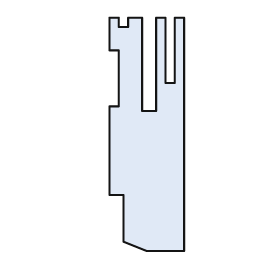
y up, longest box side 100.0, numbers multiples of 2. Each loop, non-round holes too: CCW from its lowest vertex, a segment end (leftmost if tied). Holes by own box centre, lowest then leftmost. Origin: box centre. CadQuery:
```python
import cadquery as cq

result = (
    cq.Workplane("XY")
    .moveTo(0.0, -50.0)
    .lineTo(16.0, -50.0)
    .lineTo(16.0, 50.0)
    .lineTo(12.0, 50.0)
    .lineTo(12.0, 22.0)
    .lineTo(8.0, 22.0)
    .lineTo(8.0, 50.0)
    .lineTo(4.0, 50.0)
    .lineTo(4.0, 10.0)
    .lineTo(-2.0, 10.0)
    .lineTo(-2.0, 50.0)
    .lineTo(-8.0, 50.0)
    .lineTo(-8.0, 46.0)
    .lineTo(-12.0, 46.0)
    .lineTo(-12.0, 50.0)
    .lineTo(-16.0, 50.0)
    .lineTo(-16.0, 36.0)
    .lineTo(-12.0, 36.0)
    .lineTo(-12.0, 12.0)
    .lineTo(-16.0, 12.0)
    .lineTo(-16.0, -26.0)
    .lineTo(-10.0, -26.0)
    .lineTo(-10.0, -46.0)
    .close()
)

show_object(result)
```